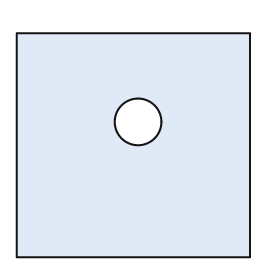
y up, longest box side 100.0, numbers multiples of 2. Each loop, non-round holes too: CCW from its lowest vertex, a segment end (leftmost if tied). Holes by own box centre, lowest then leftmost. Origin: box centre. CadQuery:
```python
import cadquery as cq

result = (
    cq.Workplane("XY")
    .moveTo(-50.0, -48.0)
    .lineTo(50.0, -48.0)
    .lineTo(50.0, 48.0)
    .lineTo(-50.0, 48.0)
    .close()
    .moveTo(2.0, 10.0)
    .circle(10.0)
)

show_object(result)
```